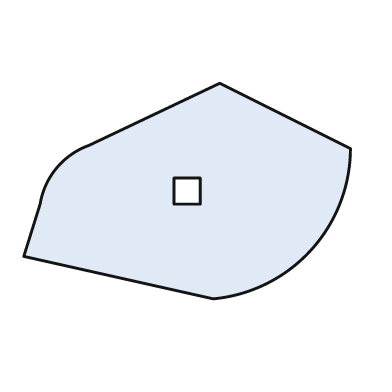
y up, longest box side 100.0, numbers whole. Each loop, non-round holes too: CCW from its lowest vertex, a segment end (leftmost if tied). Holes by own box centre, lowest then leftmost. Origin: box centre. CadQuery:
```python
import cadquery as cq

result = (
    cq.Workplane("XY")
    .moveTo(8.0, -33.0)
    .threePointArc((38.0, -18.0), (50.0, 13.0))
    .lineTo(10.0, 33.0)
    .lineTo(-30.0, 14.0)
    .threePointArc((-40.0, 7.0), (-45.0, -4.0))
    .lineTo(-50.0, -20.0)
    .close()
    .moveTo(-4.0, -4.0)
    .lineTo(4.0, -4.0)
    .lineTo(4.0, 4.0)
    .lineTo(-4.0, 4.0)
    .close()
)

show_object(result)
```